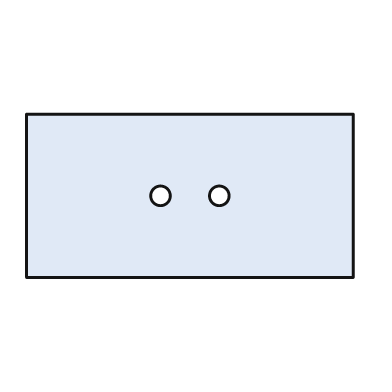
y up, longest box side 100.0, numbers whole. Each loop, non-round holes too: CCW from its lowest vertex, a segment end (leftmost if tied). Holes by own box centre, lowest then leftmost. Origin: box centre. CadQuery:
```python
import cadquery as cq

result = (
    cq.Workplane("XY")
    .moveTo(-50.0, -25.0)
    .lineTo(50.0, -25.0)
    .lineTo(50.0, 25.0)
    .lineTo(-50.0, 25.0)
    .close()
    .moveTo(-9.0, 0.0)
    .circle(3.0)
    .moveTo(9.0, 0.0)
    .circle(3.0)
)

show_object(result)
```